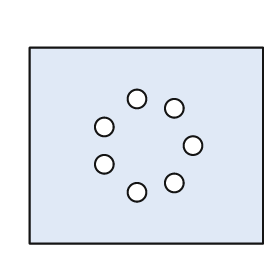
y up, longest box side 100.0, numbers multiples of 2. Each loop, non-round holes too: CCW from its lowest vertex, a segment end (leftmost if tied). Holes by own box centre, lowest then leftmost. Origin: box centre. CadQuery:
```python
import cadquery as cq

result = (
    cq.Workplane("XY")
    .moveTo(-50.0, -42.0)
    .lineTo(50.0, -42.0)
    .lineTo(50.0, 42.0)
    .lineTo(-50.0, 42.0)
    .close()
    .moveTo(-4.0, -20.0)
    .circle(4.0)
    .moveTo(12.0, -16.0)
    .circle(4.0)
    .moveTo(-18.0, -8.0)
    .circle(4.0)
    .moveTo(20.0, 0.0)
    .circle(4.0)
    .moveTo(-18.0, 8.0)
    .circle(4.0)
    .moveTo(12.0, 16.0)
    .circle(4.0)
    .moveTo(-4.0, 20.0)
    .circle(4.0)
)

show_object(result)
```